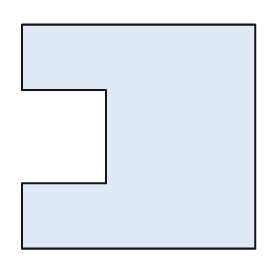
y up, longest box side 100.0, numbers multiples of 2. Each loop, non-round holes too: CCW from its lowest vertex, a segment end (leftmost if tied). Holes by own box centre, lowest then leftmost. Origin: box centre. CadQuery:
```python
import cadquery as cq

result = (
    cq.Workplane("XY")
    .moveTo(-50.0, -48.0)
    .lineTo(50.0, -48.0)
    .lineTo(50.0, 48.0)
    .lineTo(-50.0, 48.0)
    .lineTo(-50.0, 20.0)
    .lineTo(-14.0, 20.0)
    .lineTo(-14.0, -20.0)
    .lineTo(-50.0, -20.0)
    .close()
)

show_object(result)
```